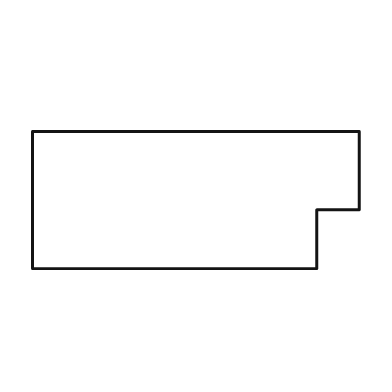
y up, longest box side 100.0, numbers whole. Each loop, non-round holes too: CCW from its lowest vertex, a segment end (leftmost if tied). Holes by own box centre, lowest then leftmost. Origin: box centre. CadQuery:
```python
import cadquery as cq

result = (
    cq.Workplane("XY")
    .moveTo(-50.0, -21.0)
    .lineTo(37.0, -21.0)
    .lineTo(37.0, -3.0)
    .lineTo(50.0, -3.0)
    .lineTo(50.0, 21.0)
    .lineTo(-50.0, 21.0)
    .close()
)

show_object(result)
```